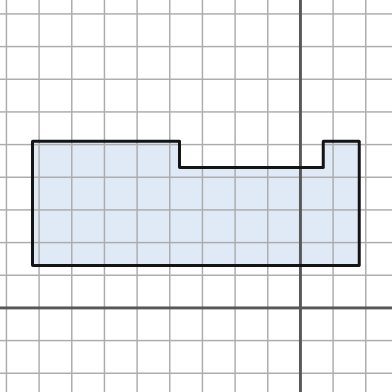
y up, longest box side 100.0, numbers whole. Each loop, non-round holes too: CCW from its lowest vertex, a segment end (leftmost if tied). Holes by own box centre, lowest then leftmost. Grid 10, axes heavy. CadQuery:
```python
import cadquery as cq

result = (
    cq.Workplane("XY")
    .moveTo(-82.0, 13.0)
    .lineTo(18.0, 13.0)
    .lineTo(18.0, 51.0)
    .lineTo(7.0, 51.0)
    .lineTo(7.0, 43.0)
    .lineTo(-37.0, 43.0)
    .lineTo(-37.0, 51.0)
    .lineTo(-82.0, 51.0)
    .close()
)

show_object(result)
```